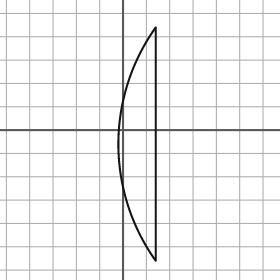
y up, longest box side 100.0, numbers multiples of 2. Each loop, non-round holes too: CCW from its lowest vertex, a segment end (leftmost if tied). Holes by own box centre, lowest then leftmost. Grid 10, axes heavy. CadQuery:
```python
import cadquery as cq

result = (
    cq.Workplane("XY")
    .moveTo(14.0, -56.0)
    .lineTo(14.0, 44.0)
    .threePointArc((-2.0, -6.0), (14.0, -56.0))
    .close()
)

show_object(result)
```